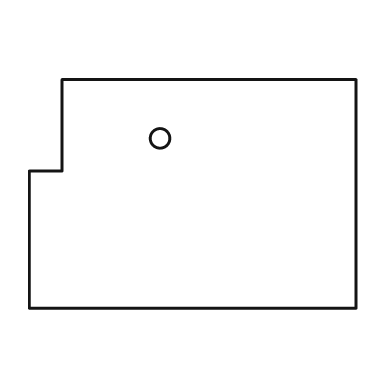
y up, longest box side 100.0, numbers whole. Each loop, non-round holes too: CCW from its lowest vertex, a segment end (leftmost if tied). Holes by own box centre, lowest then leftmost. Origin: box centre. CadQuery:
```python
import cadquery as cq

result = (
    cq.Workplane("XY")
    .moveTo(-50.0, -35.0)
    .lineTo(50.0, -35.0)
    .lineTo(50.0, 35.0)
    .lineTo(-40.0, 35.0)
    .lineTo(-40.0, 7.0)
    .lineTo(-50.0, 7.0)
    .close()
    .moveTo(-10.0, 17.0)
    .circle(3.0)
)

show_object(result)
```